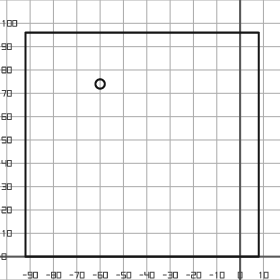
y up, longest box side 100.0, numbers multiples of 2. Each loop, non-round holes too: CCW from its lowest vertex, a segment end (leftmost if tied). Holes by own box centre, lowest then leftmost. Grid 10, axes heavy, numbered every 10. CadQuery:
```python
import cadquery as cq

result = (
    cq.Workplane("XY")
    .moveTo(-92.0, 0.0)
    .lineTo(8.0, 0.0)
    .lineTo(8.0, 96.0)
    .lineTo(-92.0, 96.0)
    .close()
    .moveTo(-60.0, 74.0)
    .circle(2.0)
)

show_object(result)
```